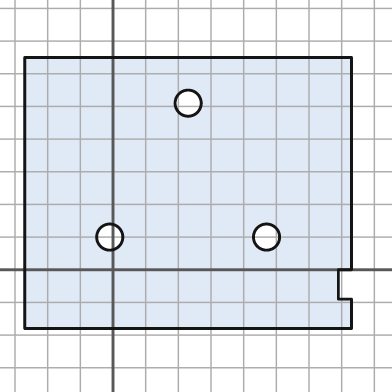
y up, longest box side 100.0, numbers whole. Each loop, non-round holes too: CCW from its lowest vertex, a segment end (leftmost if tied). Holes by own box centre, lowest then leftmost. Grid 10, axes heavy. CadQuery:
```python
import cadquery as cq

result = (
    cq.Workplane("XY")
    .moveTo(-27.0, -18.0)
    .lineTo(73.0, -18.0)
    .lineTo(73.0, -9.0)
    .lineTo(69.0, -9.0)
    .lineTo(69.0, 0.0)
    .lineTo(73.0, 0.0)
    .lineTo(73.0, 65.0)
    .lineTo(-27.0, 65.0)
    .close()
    .moveTo(-1.0, 10.0)
    .circle(4.0)
    .moveTo(47.0, 10.0)
    .circle(4.0)
    .moveTo(23.0, 51.0)
    .circle(4.0)
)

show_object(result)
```